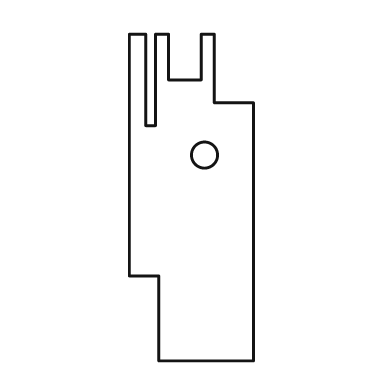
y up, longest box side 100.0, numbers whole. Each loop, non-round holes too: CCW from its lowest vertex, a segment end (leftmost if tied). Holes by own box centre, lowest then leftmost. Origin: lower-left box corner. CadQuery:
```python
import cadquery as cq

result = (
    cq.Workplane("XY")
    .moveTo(9.0, 0.0)
    .lineTo(38.0, 0.0)
    .lineTo(38.0, 79.0)
    .lineTo(26.0, 79.0)
    .lineTo(26.0, 100.0)
    .lineTo(22.0, 100.0)
    .lineTo(22.0, 86.0)
    .lineTo(12.0, 86.0)
    .lineTo(12.0, 100.0)
    .lineTo(8.0, 100.0)
    .lineTo(8.0, 72.0)
    .lineTo(5.0, 72.0)
    .lineTo(5.0, 100.0)
    .lineTo(0.0, 100.0)
    .lineTo(0.0, 26.0)
    .lineTo(9.0, 26.0)
    .close()
    .moveTo(23.0, 63.0)
    .circle(4.0)
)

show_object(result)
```